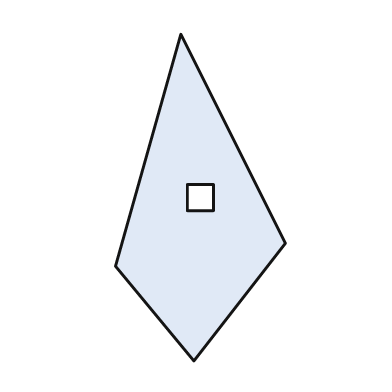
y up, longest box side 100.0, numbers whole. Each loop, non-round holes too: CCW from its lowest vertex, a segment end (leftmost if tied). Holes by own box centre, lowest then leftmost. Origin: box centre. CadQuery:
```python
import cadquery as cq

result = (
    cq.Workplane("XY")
    .moveTo(-2.0, -50.0)
    .lineTo(26.0, -14.0)
    .lineTo(-6.0, 50.0)
    .lineTo(-26.0, -21.0)
    .close()
    .moveTo(-4.0, -4.0)
    .lineTo(4.0, -4.0)
    .lineTo(4.0, 4.0)
    .lineTo(-4.0, 4.0)
    .close()
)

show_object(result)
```